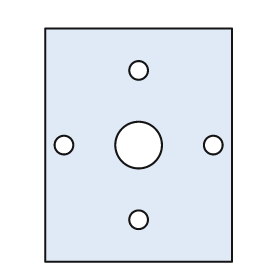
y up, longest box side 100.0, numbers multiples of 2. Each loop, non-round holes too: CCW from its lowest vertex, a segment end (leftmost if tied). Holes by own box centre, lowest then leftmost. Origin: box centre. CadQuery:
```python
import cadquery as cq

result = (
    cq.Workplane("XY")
    .moveTo(-40.0, -50.0)
    .lineTo(40.0, -50.0)
    .lineTo(40.0, 50.0)
    .lineTo(-40.0, 50.0)
    .close()
    .moveTo(0.0, -32.0)
    .circle(4.0)
    .moveTo(-32.0, 0.0)
    .circle(4.0)
    .moveTo(0.0, 0.0)
    .circle(10.0)
    .moveTo(32.0, 0.0)
    .circle(4.0)
    .moveTo(0.0, 32.0)
    .circle(4.0)
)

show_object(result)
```